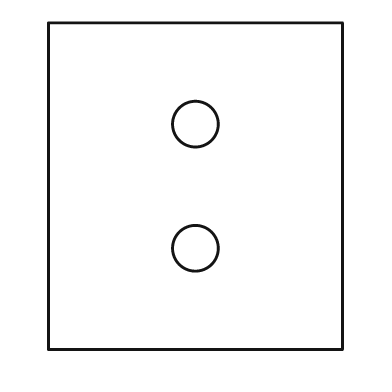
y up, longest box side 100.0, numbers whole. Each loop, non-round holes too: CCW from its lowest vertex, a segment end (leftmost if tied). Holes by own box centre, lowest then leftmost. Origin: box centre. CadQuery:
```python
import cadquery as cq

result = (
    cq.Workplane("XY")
    .moveTo(-45.0, -50.0)
    .lineTo(45.0, -50.0)
    .lineTo(45.0, 50.0)
    .lineTo(-45.0, 50.0)
    .close()
    .moveTo(0.0, -19.0)
    .circle(7.0)
    .moveTo(0.0, 19.0)
    .circle(7.0)
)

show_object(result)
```